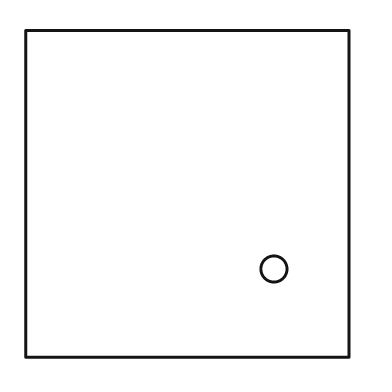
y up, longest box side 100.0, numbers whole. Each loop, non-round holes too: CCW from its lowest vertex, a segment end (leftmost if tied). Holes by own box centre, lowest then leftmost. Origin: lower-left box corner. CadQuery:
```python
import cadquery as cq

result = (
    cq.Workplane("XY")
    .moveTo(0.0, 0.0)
    .lineTo(99.0, 0.0)
    .lineTo(99.0, 100.0)
    .lineTo(0.0, 100.0)
    .close()
    .moveTo(76.0, 27.0)
    .circle(4.0)
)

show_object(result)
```